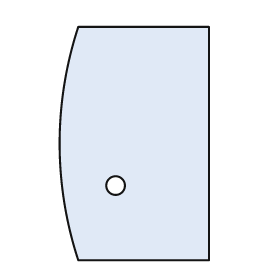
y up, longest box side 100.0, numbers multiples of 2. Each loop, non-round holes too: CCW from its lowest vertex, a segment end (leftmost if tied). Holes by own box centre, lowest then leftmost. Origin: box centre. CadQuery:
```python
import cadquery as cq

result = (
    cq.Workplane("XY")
    .moveTo(-24.0, -50.0)
    .lineTo(32.0, -50.0)
    .lineTo(32.0, 50.0)
    .lineTo(-24.0, 50.0)
    .threePointArc((-32.0, 0.0), (-24.0, -50.0))
    .close()
    .moveTo(-8.0, -18.0)
    .circle(4.0)
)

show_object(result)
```